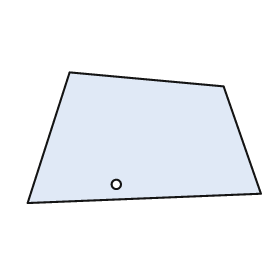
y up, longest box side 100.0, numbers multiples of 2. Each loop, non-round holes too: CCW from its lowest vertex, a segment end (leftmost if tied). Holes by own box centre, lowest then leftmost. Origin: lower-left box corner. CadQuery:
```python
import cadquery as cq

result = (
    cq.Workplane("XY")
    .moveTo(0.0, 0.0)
    .lineTo(100.0, 4.0)
    .lineTo(84.0, 50.0)
    .lineTo(18.0, 56.0)
    .close()
    .moveTo(38.0, 8.0)
    .circle(2.0)
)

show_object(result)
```